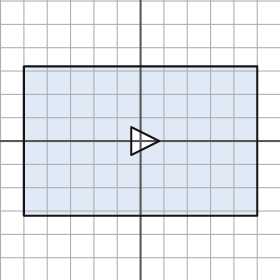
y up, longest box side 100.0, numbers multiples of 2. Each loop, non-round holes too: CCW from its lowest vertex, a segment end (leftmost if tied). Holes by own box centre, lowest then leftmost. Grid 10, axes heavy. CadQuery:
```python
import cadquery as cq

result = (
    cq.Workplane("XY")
    .moveTo(-50.0, -32.0)
    .lineTo(50.0, -32.0)
    .lineTo(50.0, 32.0)
    .lineTo(-50.0, 32.0)
    .close()
    .moveTo(-4.0, -6.0)
    .lineTo(8.0, 0.0)
    .lineTo(-4.0, 6.0)
    .close()
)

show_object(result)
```